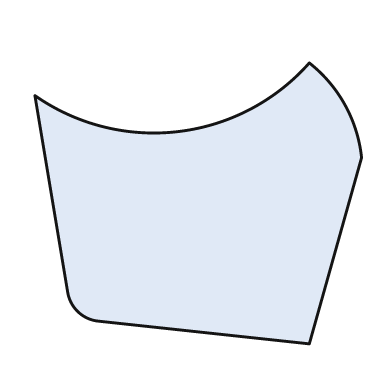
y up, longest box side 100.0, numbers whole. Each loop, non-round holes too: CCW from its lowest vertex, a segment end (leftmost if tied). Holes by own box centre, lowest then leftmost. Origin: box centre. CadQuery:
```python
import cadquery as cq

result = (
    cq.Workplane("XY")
    .moveTo(34.0, -43.0)
    .lineTo(50.0, 14.0)
    .threePointArc((45.0, 30.0), (34.0, 43.0))
    .threePointArc((-6.0, 22.0), (-50.0, 33.0))
    .lineTo(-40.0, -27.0)
    .threePointArc((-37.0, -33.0), (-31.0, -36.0))
    .close()
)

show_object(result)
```